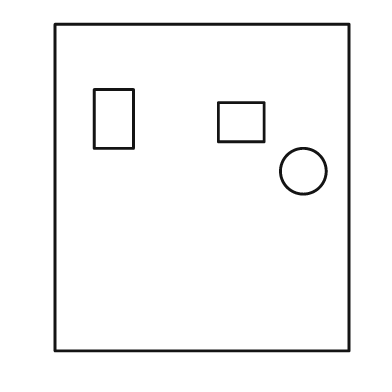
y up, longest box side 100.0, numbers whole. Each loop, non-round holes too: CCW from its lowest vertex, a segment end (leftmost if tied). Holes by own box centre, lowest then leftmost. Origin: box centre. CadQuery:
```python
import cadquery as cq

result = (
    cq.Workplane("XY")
    .moveTo(-45.0, -50.0)
    .lineTo(45.0, -50.0)
    .lineTo(45.0, 50.0)
    .lineTo(-45.0, 50.0)
    .close()
    .moveTo(31.0, 5.0)
    .circle(7.0)
    .moveTo(5.0, 14.0)
    .lineTo(19.0, 14.0)
    .lineTo(19.0, 26.0)
    .lineTo(5.0, 26.0)
    .close()
    .moveTo(-33.0, 12.0)
    .lineTo(-21.0, 12.0)
    .lineTo(-21.0, 30.0)
    .lineTo(-33.0, 30.0)
    .close()
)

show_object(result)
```